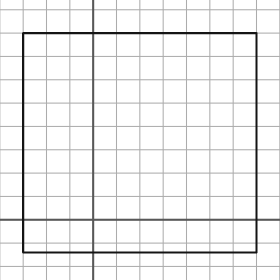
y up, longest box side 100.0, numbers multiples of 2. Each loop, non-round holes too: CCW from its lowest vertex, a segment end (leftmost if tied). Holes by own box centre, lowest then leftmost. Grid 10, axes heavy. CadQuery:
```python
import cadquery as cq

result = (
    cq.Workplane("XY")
    .moveTo(-30.0, -14.0)
    .lineTo(70.0, -14.0)
    .lineTo(70.0, 80.0)
    .lineTo(-30.0, 80.0)
    .close()
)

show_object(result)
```